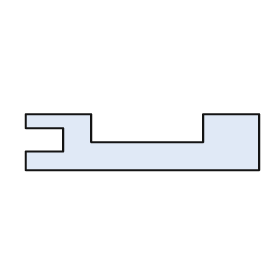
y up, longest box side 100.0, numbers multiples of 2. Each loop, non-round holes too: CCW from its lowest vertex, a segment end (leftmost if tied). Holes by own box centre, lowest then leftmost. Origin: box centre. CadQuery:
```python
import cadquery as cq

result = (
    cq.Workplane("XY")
    .moveTo(-50.0, -12.0)
    .lineTo(50.0, -12.0)
    .lineTo(50.0, 12.0)
    .lineTo(26.0, 12.0)
    .lineTo(26.0, 0.0)
    .lineTo(-22.0, 0.0)
    .lineTo(-22.0, 12.0)
    .lineTo(-50.0, 12.0)
    .lineTo(-50.0, 6.0)
    .lineTo(-34.0, 6.0)
    .lineTo(-34.0, -4.0)
    .lineTo(-50.0, -4.0)
    .close()
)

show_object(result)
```